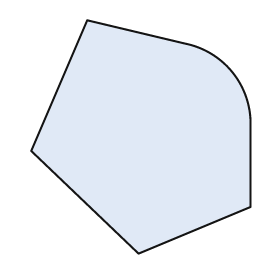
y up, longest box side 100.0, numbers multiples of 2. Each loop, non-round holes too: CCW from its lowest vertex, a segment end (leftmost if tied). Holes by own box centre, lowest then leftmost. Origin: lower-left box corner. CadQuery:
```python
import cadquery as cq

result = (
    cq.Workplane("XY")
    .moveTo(46.0, 0.0)
    .lineTo(94.0, 20.0)
    .lineTo(94.0, 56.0)
    .threePointArc((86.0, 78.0), (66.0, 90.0))
    .lineTo(24.0, 100.0)
    .lineTo(0.0, 44.0)
    .close()
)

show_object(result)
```